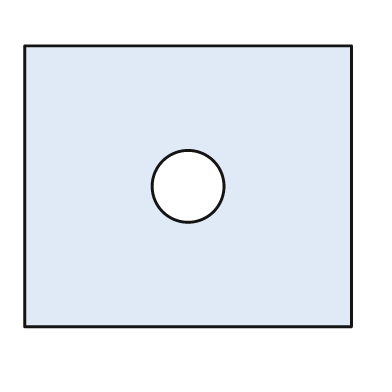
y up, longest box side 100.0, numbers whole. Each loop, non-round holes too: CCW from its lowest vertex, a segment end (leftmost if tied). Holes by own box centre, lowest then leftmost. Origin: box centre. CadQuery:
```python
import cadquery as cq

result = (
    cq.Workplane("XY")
    .moveTo(-50.0, -43.0)
    .lineTo(50.0, -43.0)
    .lineTo(50.0, 43.0)
    .lineTo(-50.0, 43.0)
    .close()
    .moveTo(0.0, 0.0)
    .circle(11.0)
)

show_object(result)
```